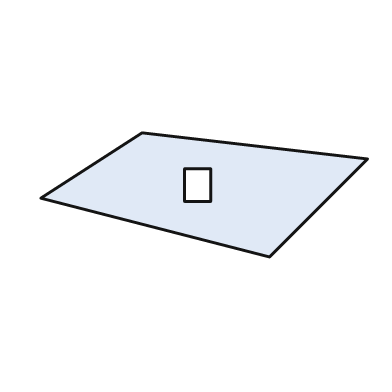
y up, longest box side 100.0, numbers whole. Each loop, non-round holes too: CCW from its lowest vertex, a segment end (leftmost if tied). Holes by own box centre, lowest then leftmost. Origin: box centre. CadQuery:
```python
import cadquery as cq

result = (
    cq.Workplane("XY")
    .moveTo(20.0, -19.0)
    .lineTo(50.0, 11.0)
    .lineTo(-19.0, 19.0)
    .lineTo(-50.0, -1.0)
    .close()
    .moveTo(-6.0, -2.0)
    .lineTo(2.0, -2.0)
    .lineTo(2.0, 8.0)
    .lineTo(-6.0, 8.0)
    .close()
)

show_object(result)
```